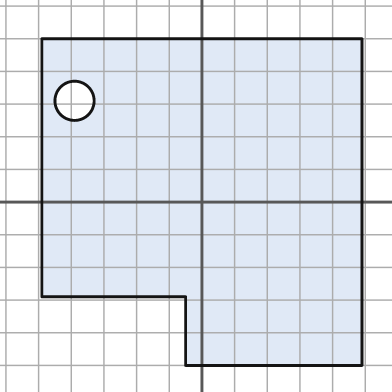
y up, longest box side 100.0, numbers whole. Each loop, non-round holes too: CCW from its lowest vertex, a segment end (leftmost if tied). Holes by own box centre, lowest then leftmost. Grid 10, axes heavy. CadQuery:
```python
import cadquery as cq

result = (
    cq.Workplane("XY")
    .moveTo(-5.0, -50.0)
    .lineTo(49.0, -50.0)
    .lineTo(49.0, 50.0)
    .lineTo(-49.0, 50.0)
    .lineTo(-49.0, -29.0)
    .lineTo(-5.0, -29.0)
    .close()
    .moveTo(-39.0, 31.0)
    .circle(6.0)
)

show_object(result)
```